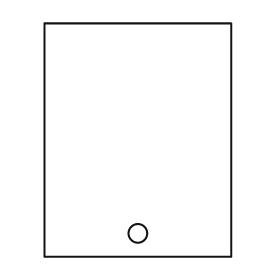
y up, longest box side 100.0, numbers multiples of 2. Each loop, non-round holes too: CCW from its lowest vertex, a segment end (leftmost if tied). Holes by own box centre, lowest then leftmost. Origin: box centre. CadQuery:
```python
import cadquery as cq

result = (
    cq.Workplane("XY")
    .moveTo(-40.0, -50.0)
    .lineTo(40.0, -50.0)
    .lineTo(40.0, 50.0)
    .lineTo(-40.0, 50.0)
    .close()
    .moveTo(0.0, -40.0)
    .circle(4.0)
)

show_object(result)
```